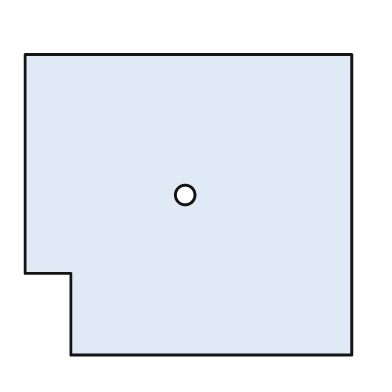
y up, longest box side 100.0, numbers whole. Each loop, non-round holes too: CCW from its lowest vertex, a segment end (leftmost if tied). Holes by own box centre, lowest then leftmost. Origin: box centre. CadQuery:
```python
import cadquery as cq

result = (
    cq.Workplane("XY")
    .moveTo(-36.0, -46.0)
    .lineTo(50.0, -46.0)
    .lineTo(50.0, 46.0)
    .lineTo(-50.0, 46.0)
    .lineTo(-50.0, -21.0)
    .lineTo(-36.0, -21.0)
    .close()
    .moveTo(-1.0, 3.0)
    .circle(3.0)
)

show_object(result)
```